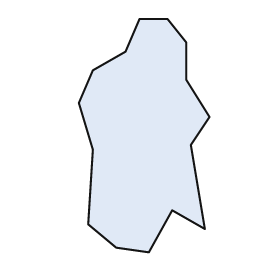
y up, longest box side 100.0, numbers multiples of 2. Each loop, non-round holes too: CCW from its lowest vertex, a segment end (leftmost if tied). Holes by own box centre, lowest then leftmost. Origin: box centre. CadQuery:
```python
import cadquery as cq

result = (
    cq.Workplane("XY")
    .moveTo(2.0, -50.0)
    .lineTo(12.0, -32.0)
    .lineTo(26.0, -40.0)
    .lineTo(20.0, -4.0)
    .lineTo(28.0, 8.0)
    .lineTo(18.0, 24.0)
    .lineTo(18.0, 40.0)
    .lineTo(10.0, 50.0)
    .lineTo(-2.0, 50.0)
    .lineTo(-8.0, 36.0)
    .lineTo(-22.0, 28.0)
    .lineTo(-28.0, 14.0)
    .lineTo(-22.0, -6.0)
    .lineTo(-24.0, -38.0)
    .lineTo(-12.0, -48.0)
    .close()
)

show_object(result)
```